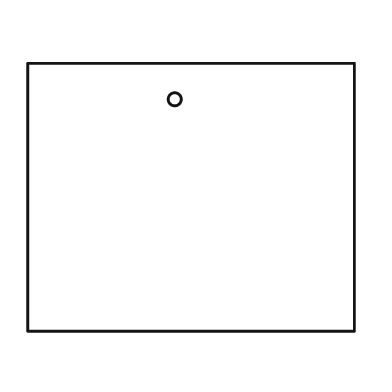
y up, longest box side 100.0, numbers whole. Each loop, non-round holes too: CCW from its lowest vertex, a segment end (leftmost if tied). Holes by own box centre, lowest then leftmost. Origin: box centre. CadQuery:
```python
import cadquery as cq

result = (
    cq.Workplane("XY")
    .moveTo(-50.0, -41.0)
    .lineTo(50.0, -41.0)
    .lineTo(50.0, 41.0)
    .lineTo(-50.0, 41.0)
    .close()
    .moveTo(-5.0, 30.0)
    .circle(2.0)
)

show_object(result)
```